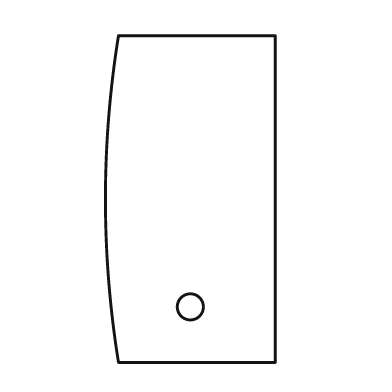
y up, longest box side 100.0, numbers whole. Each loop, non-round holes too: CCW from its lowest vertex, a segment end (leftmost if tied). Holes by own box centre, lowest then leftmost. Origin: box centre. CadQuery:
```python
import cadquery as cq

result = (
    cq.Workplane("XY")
    .moveTo(-22.0, -50.0)
    .lineTo(26.0, -50.0)
    .lineTo(26.0, 50.0)
    .lineTo(-22.0, 50.0)
    .threePointArc((-26.0, 0.0), (-22.0, -50.0))
    .close()
    .moveTo(0.0, -33.0)
    .circle(4.0)
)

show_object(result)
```